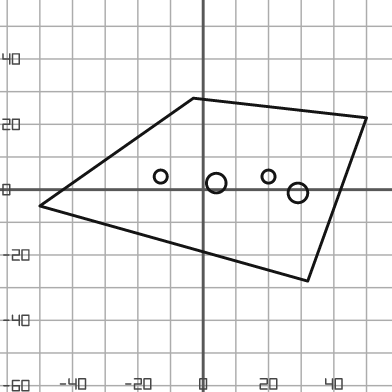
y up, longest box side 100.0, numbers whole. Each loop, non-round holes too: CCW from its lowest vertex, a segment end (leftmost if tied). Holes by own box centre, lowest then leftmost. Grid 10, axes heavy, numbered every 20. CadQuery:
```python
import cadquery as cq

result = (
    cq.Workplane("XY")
    .moveTo(32.0, -28.0)
    .lineTo(50.0, 22.0)
    .lineTo(-3.0, 28.0)
    .lineTo(-50.0, -5.0)
    .close()
    .moveTo(29.0, -1.0)
    .circle(3.0)
    .moveTo(4.0, 2.0)
    .circle(3.0)
    .moveTo(-13.0, 4.0)
    .circle(2.0)
    .moveTo(20.0, 4.0)
    .circle(2.0)
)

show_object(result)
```